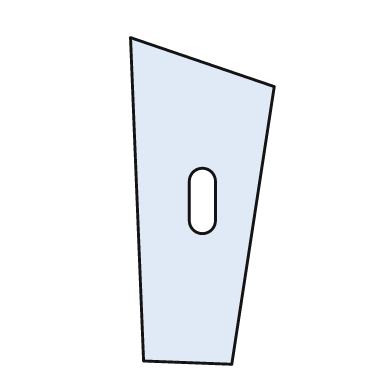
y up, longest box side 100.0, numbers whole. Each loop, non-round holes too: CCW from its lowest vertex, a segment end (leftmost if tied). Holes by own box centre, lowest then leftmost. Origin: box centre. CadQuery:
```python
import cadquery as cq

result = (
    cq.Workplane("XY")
    .moveTo(9.0, -50.0)
    .lineTo(22.0, 35.0)
    .lineTo(-22.0, 50.0)
    .lineTo(-18.0, -49.0)
    .close()
    .moveTo(-4.0, -6.0)
    .threePointArc((0.0, -10.0), (4.0, -6.0))
    .lineTo(4.0, 6.0)
    .threePointArc((0.0, 10.0), (-4.0, 6.0))
    .close()
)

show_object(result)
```